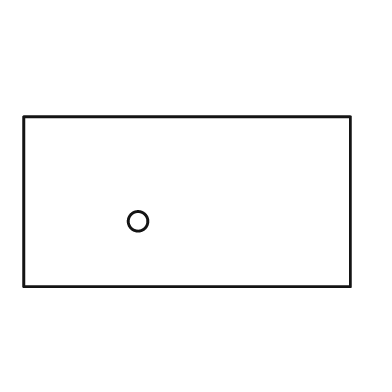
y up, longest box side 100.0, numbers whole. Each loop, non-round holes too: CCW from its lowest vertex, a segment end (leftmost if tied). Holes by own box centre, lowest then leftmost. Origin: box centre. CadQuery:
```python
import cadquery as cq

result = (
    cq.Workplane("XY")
    .moveTo(-50.0, -26.0)
    .lineTo(50.0, -26.0)
    .lineTo(50.0, 26.0)
    .lineTo(-50.0, 26.0)
    .close()
    .moveTo(-15.0, -6.0)
    .circle(3.0)
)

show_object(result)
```